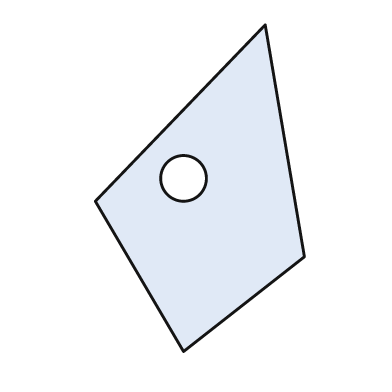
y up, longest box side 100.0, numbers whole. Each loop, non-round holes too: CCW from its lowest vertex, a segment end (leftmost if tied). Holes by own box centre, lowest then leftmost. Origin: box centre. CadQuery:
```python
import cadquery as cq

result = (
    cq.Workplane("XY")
    .moveTo(-5.0, -50.0)
    .lineTo(32.0, -21.0)
    .lineTo(20.0, 50.0)
    .lineTo(-32.0, -4.0)
    .close()
    .moveTo(-5.0, 3.0)
    .circle(7.0)
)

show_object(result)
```